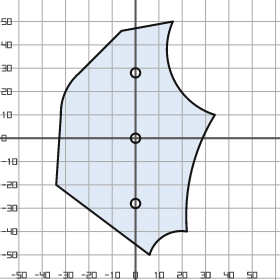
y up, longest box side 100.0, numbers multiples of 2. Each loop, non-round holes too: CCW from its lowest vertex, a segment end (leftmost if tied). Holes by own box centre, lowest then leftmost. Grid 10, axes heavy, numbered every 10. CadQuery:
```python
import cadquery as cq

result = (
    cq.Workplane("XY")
    .moveTo(6.0, -50.0)
    .threePointArc((12.0, -42.0), (22.0, -40.0))
    .threePointArc((24.0, -14.0), (34.0, 10.0))
    .threePointArc((16.0, 26.0), (16.0, 50.0))
    .lineTo(-6.0, 46.0)
    .lineTo(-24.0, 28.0)
    .threePointArc((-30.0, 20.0), (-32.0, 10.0))
    .lineTo(-34.0, -20.0)
    .close()
    .moveTo(0.0, -28.0)
    .circle(2.0)
    .moveTo(0.0, 0.0)
    .circle(2.0)
    .moveTo(0.0, 28.0)
    .circle(2.0)
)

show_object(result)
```